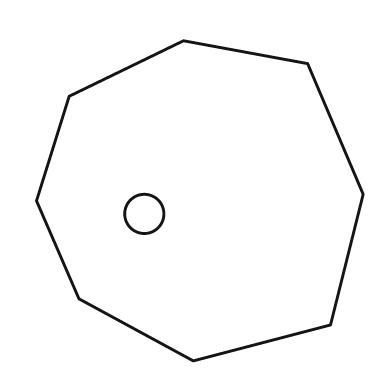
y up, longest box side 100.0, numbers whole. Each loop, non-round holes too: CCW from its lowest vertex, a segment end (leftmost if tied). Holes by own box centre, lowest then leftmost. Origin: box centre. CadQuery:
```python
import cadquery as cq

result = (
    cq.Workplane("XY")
    .moveTo(-2.0, -49.0)
    .lineTo(40.0, -38.0)
    .lineTo(50.0, 2.0)
    .lineTo(33.0, 42.0)
    .lineTo(-5.0, 49.0)
    .lineTo(-40.0, 32.0)
    .lineTo(-50.0, 0.0)
    .lineTo(-37.0, -30.0)
    .close()
    .moveTo(-17.0, -4.0)
    .circle(6.0)
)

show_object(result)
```